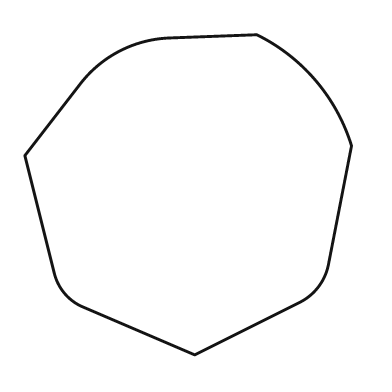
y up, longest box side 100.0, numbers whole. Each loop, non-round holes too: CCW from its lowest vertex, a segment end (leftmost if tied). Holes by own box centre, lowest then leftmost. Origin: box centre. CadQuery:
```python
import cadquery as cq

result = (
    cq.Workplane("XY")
    .moveTo(2.0, -49.0)
    .lineTo(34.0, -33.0)
    .threePointArc((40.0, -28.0), (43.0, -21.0))
    .lineTo(50.0, 15.0)
    .threePointArc((39.0, 35.0), (21.0, 49.0))
    .lineTo(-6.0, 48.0)
    .threePointArc((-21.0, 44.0), (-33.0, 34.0))
    .lineTo(-50.0, 12.0)
    .lineTo(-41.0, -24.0)
    .threePointArc((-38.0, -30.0), (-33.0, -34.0))
    .close()
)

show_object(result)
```